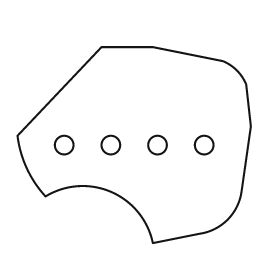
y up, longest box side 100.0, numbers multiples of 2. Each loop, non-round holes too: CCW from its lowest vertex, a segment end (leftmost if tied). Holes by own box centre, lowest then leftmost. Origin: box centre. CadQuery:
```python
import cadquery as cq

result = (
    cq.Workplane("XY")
    .moveTo(8.0, -42.0)
    .lineTo(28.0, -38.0)
    .threePointArc((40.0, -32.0), (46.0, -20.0))
    .lineTo(50.0, 8.0)
    .lineTo(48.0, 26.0)
    .threePointArc((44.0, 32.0), (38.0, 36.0))
    .lineTo(8.0, 42.0)
    .lineTo(-14.0, 42.0)
    .lineTo(-50.0, 4.0)
    .threePointArc((-46.0, -10.0), (-38.0, -22.0))
    .threePointArc((-10.0, -20.0), (8.0, -42.0))
    .close()
    .moveTo(-30.0, 0.0)
    .circle(4.0)
    .moveTo(-10.0, 0.0)
    .circle(4.0)
    .moveTo(10.0, 0.0)
    .circle(4.0)
    .moveTo(30.0, 0.0)
    .circle(4.0)
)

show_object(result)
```